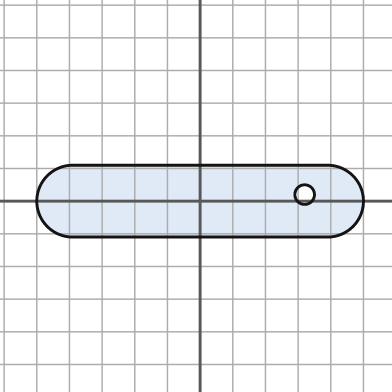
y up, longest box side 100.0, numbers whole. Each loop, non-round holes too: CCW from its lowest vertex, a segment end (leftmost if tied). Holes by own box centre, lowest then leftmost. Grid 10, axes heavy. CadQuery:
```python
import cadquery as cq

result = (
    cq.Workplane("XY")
    .moveTo(-39.0, -11.0)
    .lineTo(39.0, -11.0)
    .threePointArc((50.0, 0.0), (39.0, 11.0))
    .lineTo(-39.0, 11.0)
    .threePointArc((-50.0, 0.0), (-39.0, -11.0))
    .close()
    .moveTo(32.0, 2.0)
    .circle(3.0)
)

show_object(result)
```